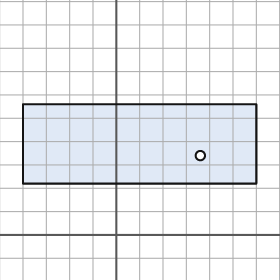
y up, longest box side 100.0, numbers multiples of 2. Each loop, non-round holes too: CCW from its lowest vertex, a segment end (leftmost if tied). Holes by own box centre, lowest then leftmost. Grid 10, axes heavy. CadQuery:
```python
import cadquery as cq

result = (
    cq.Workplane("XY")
    .moveTo(-40.0, 22.0)
    .lineTo(60.0, 22.0)
    .lineTo(60.0, 56.0)
    .lineTo(-40.0, 56.0)
    .close()
    .moveTo(36.0, 34.0)
    .circle(2.0)
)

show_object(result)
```